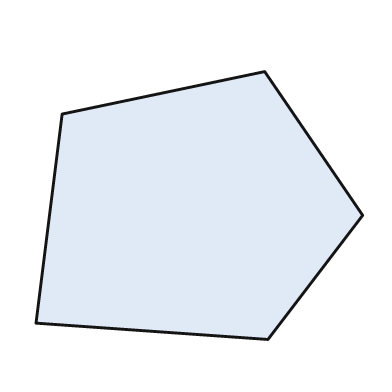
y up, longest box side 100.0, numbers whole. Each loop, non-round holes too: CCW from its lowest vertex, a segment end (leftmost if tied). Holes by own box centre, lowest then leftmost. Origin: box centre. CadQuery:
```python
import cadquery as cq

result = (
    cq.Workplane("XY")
    .moveTo(21.0, -41.0)
    .lineTo(50.0, -3.0)
    .lineTo(20.0, 41.0)
    .lineTo(-42.0, 28.0)
    .lineTo(-50.0, -36.0)
    .close()
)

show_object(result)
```